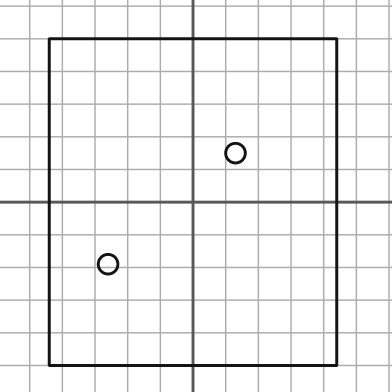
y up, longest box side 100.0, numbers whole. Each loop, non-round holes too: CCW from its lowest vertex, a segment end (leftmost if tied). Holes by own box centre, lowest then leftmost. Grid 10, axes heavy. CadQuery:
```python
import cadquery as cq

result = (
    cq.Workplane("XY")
    .moveTo(-44.0, -50.0)
    .lineTo(44.0, -50.0)
    .lineTo(44.0, 50.0)
    .lineTo(-44.0, 50.0)
    .close()
    .moveTo(-26.0, -19.0)
    .circle(3.0)
    .moveTo(13.0, 15.0)
    .circle(3.0)
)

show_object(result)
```